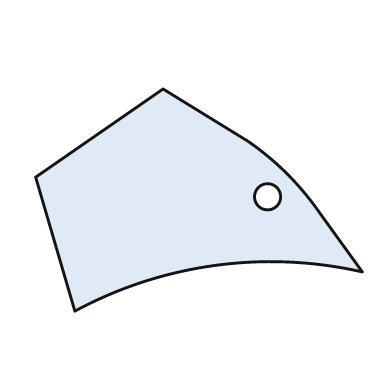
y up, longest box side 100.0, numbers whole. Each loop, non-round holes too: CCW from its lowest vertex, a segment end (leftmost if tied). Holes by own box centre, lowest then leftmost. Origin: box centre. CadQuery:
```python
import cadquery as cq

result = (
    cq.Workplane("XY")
    .moveTo(-38.0, -34.0)
    .threePointArc((5.0, -20.0), (50.0, -22.0))
    .lineTo(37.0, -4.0)
    .threePointArc((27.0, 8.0), (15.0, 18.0))
    .lineTo(-11.0, 34.0)
    .lineTo(-50.0, 7.0)
    .close()
    .moveTo(21.0, 1.0)
    .circle(4.0)
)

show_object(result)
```